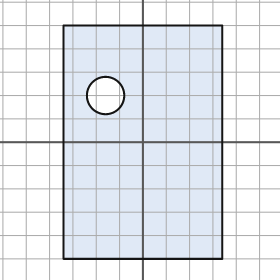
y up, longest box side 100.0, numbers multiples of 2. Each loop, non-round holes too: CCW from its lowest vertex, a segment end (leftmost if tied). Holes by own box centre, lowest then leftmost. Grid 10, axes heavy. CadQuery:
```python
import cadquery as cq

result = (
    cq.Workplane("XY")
    .moveTo(-34.0, -50.0)
    .lineTo(34.0, -50.0)
    .lineTo(34.0, 50.0)
    .lineTo(-34.0, 50.0)
    .close()
    .moveTo(-16.0, 20.0)
    .circle(8.0)
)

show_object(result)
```